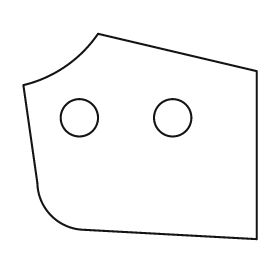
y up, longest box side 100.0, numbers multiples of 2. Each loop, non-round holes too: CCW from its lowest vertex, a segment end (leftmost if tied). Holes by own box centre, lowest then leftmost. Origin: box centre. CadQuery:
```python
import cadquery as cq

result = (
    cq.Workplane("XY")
    .moveTo(50.0, -44.0)
    .lineTo(50.0, 28.0)
    .lineTo(-18.0, 44.0)
    .threePointArc((-32.0, 30.0), (-50.0, 22.0))
    .lineTo(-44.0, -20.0)
    .threePointArc((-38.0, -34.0), (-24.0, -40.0))
    .close()
    .moveTo(-26.0, 8.0)
    .circle(8.0)
    .moveTo(14.0, 8.0)
    .circle(8.0)
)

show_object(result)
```